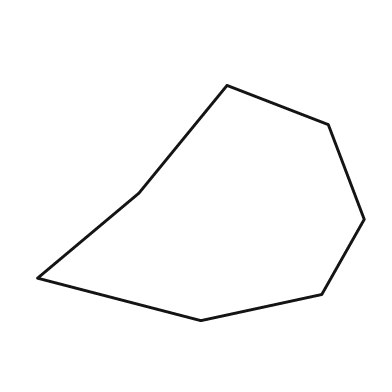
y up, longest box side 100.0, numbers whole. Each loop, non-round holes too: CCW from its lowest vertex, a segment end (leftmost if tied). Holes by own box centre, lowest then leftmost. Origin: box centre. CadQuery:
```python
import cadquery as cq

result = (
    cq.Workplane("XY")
    .moveTo(0.0, -36.0)
    .lineTo(37.0, -28.0)
    .lineTo(50.0, -5.0)
    .lineTo(39.0, 24.0)
    .lineTo(8.0, 36.0)
    .lineTo(-19.0, 3.0)
    .lineTo(-50.0, -23.0)
    .close()
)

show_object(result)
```